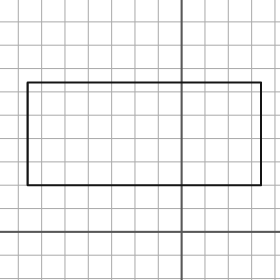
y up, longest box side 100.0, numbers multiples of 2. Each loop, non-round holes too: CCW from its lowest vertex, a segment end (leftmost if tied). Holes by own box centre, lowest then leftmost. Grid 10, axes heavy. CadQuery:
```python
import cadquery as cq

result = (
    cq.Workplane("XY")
    .moveTo(-66.0, 20.0)
    .lineTo(34.0, 20.0)
    .lineTo(34.0, 64.0)
    .lineTo(-66.0, 64.0)
    .close()
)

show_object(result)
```